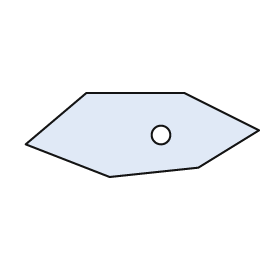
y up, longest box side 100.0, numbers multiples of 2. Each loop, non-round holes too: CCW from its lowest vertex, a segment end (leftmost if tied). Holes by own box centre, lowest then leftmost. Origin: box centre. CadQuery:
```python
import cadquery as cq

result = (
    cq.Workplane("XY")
    .moveTo(-14.0, -18.0)
    .lineTo(24.0, -14.0)
    .lineTo(50.0, 2.0)
    .lineTo(18.0, 18.0)
    .lineTo(-24.0, 18.0)
    .lineTo(-50.0, -4.0)
    .close()
    .moveTo(8.0, 0.0)
    .circle(4.0)
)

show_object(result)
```